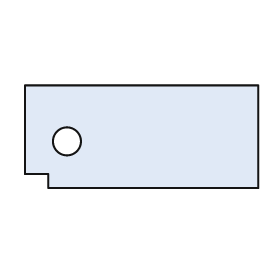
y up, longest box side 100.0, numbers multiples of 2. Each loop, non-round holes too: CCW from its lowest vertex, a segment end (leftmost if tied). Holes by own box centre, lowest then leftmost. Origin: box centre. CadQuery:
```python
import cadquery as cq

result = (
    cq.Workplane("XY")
    .moveTo(-40.0, -22.0)
    .lineTo(50.0, -22.0)
    .lineTo(50.0, 22.0)
    .lineTo(-50.0, 22.0)
    .lineTo(-50.0, -16.0)
    .lineTo(-40.0, -16.0)
    .close()
    .moveTo(-32.0, -2.0)
    .circle(6.0)
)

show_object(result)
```